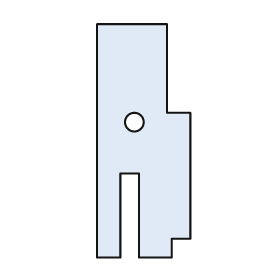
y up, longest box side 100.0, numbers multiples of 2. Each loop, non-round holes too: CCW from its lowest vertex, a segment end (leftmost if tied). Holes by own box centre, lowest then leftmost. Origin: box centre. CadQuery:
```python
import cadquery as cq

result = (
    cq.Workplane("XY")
    .moveTo(-20.0, -50.0)
    .lineTo(-10.0, -50.0)
    .lineTo(-10.0, -14.0)
    .lineTo(-2.0, -14.0)
    .lineTo(-2.0, -50.0)
    .lineTo(12.0, -50.0)
    .lineTo(12.0, -42.0)
    .lineTo(20.0, -42.0)
    .lineTo(20.0, 12.0)
    .lineTo(10.0, 12.0)
    .lineTo(10.0, 50.0)
    .lineTo(-20.0, 50.0)
    .close()
    .moveTo(-4.0, 8.0)
    .circle(4.0)
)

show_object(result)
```